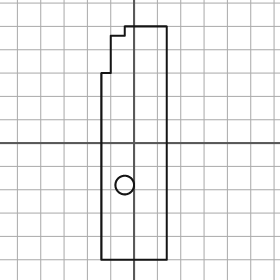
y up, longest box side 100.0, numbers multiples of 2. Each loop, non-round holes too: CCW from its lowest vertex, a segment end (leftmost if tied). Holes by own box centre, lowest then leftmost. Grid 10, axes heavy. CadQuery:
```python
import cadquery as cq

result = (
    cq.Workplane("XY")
    .moveTo(-14.0, -50.0)
    .lineTo(14.0, -50.0)
    .lineTo(14.0, 50.0)
    .lineTo(-4.0, 50.0)
    .lineTo(-4.0, 46.0)
    .lineTo(-10.0, 46.0)
    .lineTo(-10.0, 30.0)
    .lineTo(-14.0, 30.0)
    .close()
    .moveTo(-4.0, -18.0)
    .circle(4.0)
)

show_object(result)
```